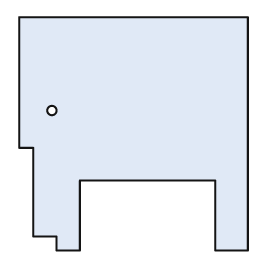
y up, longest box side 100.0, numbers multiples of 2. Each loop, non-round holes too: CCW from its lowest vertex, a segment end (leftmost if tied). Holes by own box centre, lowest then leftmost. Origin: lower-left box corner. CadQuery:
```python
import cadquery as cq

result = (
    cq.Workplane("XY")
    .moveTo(16.0, 0.0)
    .lineTo(26.0, 0.0)
    .lineTo(26.0, 30.0)
    .lineTo(84.0, 30.0)
    .lineTo(84.0, 0.0)
    .lineTo(98.0, 0.0)
    .lineTo(98.0, 100.0)
    .lineTo(0.0, 100.0)
    .lineTo(0.0, 44.0)
    .lineTo(6.0, 44.0)
    .lineTo(6.0, 6.0)
    .lineTo(16.0, 6.0)
    .close()
    .moveTo(14.0, 60.0)
    .circle(2.0)
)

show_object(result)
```